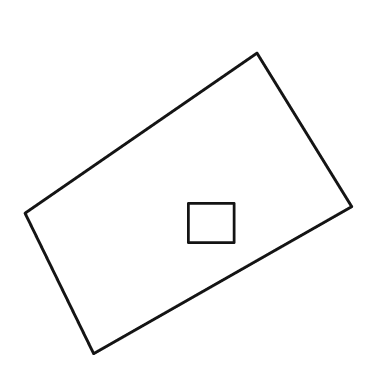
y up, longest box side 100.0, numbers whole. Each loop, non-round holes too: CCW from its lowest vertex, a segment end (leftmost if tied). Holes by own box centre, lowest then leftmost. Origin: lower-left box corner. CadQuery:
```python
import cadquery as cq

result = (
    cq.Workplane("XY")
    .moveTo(21.0, 0.0)
    .lineTo(100.0, 45.0)
    .lineTo(71.0, 92.0)
    .lineTo(0.0, 43.0)
    .close()
    .moveTo(50.0, 34.0)
    .lineTo(64.0, 34.0)
    .lineTo(64.0, 46.0)
    .lineTo(50.0, 46.0)
    .close()
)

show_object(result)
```